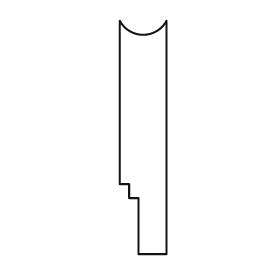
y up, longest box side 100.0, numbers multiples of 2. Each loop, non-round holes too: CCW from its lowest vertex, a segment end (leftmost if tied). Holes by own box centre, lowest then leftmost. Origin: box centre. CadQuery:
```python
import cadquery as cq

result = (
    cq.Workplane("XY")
    .moveTo(-2.0, -50.0)
    .lineTo(10.0, -50.0)
    .lineTo(10.0, 50.0)
    .threePointArc((0.0, 44.0), (-10.0, 50.0))
    .lineTo(-10.0, -20.0)
    .lineTo(-6.0, -20.0)
    .lineTo(-6.0, -26.0)
    .lineTo(-2.0, -26.0)
    .close()
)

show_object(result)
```